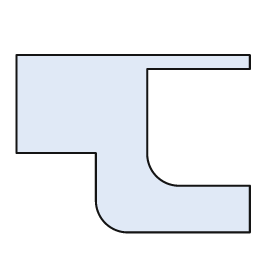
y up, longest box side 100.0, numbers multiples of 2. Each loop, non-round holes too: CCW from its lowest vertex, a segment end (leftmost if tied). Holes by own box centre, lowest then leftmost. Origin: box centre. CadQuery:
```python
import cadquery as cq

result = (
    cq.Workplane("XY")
    .moveTo(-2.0, -38.0)
    .lineTo(50.0, -38.0)
    .lineTo(50.0, -18.0)
    .lineTo(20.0, -18.0)
    .threePointArc((10.0, -14.0), (6.0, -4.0))
    .lineTo(6.0, 32.0)
    .lineTo(50.0, 32.0)
    .lineTo(50.0, 38.0)
    .lineTo(-50.0, 38.0)
    .lineTo(-50.0, -4.0)
    .lineTo(-16.0, -4.0)
    .lineTo(-16.0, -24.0)
    .threePointArc((-12.0, -34.0), (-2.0, -38.0))
    .close()
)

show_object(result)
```